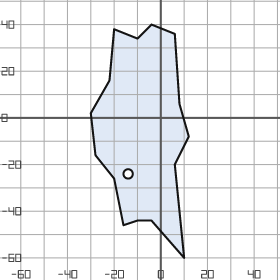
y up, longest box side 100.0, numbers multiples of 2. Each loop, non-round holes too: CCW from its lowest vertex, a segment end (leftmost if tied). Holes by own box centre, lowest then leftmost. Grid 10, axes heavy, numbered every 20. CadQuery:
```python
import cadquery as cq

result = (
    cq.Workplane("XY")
    .moveTo(10.0, -60.0)
    .lineTo(6.0, -20.0)
    .lineTo(12.0, -8.0)
    .lineTo(8.0, 6.0)
    .lineTo(6.0, 36.0)
    .lineTo(-4.0, 40.0)
    .lineTo(-10.0, 34.0)
    .lineTo(-20.0, 38.0)
    .lineTo(-22.0, 16.0)
    .lineTo(-30.0, 2.0)
    .lineTo(-28.0, -16.0)
    .lineTo(-20.0, -26.0)
    .lineTo(-16.0, -46.0)
    .lineTo(-10.0, -44.0)
    .lineTo(-4.0, -44.0)
    .close()
    .moveTo(-14.0, -24.0)
    .circle(2.0)
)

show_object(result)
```